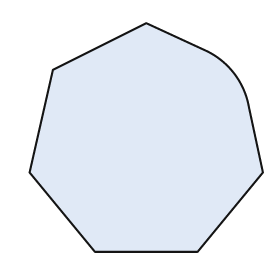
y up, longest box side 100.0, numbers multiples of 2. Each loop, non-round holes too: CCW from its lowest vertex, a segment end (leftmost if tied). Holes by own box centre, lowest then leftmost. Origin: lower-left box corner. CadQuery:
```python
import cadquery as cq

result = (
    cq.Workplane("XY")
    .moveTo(28.0, 0.0)
    .lineTo(72.0, 0.0)
    .lineTo(100.0, 34.0)
    .lineTo(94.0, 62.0)
    .threePointArc((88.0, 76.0), (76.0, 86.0))
    .lineTo(50.0, 98.0)
    .lineTo(10.0, 78.0)
    .lineTo(0.0, 34.0)
    .close()
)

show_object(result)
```